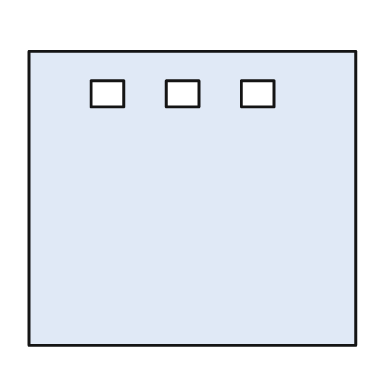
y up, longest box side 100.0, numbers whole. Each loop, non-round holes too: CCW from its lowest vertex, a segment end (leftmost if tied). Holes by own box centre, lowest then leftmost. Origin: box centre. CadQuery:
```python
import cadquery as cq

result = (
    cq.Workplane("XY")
    .moveTo(-50.0, -45.0)
    .lineTo(50.0, -45.0)
    .lineTo(50.0, 45.0)
    .lineTo(-50.0, 45.0)
    .close()
    .moveTo(-31.0, 28.0)
    .lineTo(-21.0, 28.0)
    .lineTo(-21.0, 36.0)
    .lineTo(-31.0, 36.0)
    .close()
    .moveTo(-8.0, 28.0)
    .lineTo(2.0, 28.0)
    .lineTo(2.0, 36.0)
    .lineTo(-8.0, 36.0)
    .close()
    .moveTo(15.0, 28.0)
    .lineTo(25.0, 28.0)
    .lineTo(25.0, 36.0)
    .lineTo(15.0, 36.0)
    .close()
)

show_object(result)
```